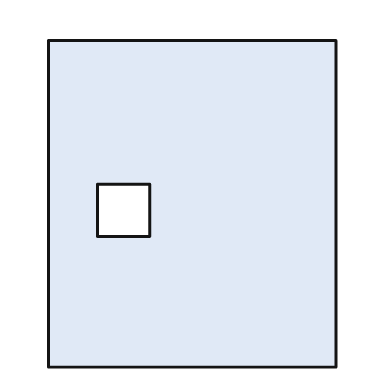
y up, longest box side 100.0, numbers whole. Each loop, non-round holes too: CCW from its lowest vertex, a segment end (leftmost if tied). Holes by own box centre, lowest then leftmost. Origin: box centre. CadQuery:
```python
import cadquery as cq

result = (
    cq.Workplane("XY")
    .moveTo(-44.0, -50.0)
    .lineTo(44.0, -50.0)
    .lineTo(44.0, 50.0)
    .lineTo(-44.0, 50.0)
    .close()
    .moveTo(-29.0, -10.0)
    .lineTo(-13.0, -10.0)
    .lineTo(-13.0, 6.0)
    .lineTo(-29.0, 6.0)
    .close()
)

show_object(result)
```